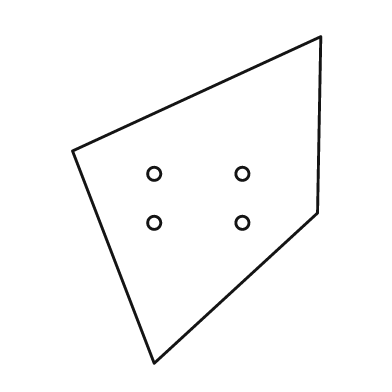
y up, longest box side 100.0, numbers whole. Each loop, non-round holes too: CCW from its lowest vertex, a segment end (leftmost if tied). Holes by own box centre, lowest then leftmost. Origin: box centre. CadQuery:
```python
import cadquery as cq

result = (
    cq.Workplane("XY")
    .moveTo(-13.0, -50.0)
    .lineTo(37.0, -4.0)
    .lineTo(38.0, 50.0)
    .lineTo(-38.0, 15.0)
    .close()
    .moveTo(-13.0, -7.0)
    .circle(2.0)
    .moveTo(14.0, -7.0)
    .circle(2.0)
    .moveTo(-13.0, 8.0)
    .circle(2.0)
    .moveTo(14.0, 8.0)
    .circle(2.0)
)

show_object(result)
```